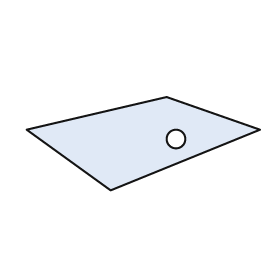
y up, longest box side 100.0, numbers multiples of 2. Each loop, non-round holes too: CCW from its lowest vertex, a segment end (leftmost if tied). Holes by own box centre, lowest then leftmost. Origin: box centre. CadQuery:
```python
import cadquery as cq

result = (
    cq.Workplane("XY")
    .moveTo(-14.0, -20.0)
    .lineTo(50.0, 6.0)
    .lineTo(10.0, 20.0)
    .lineTo(-50.0, 6.0)
    .close()
    .moveTo(14.0, 2.0)
    .circle(4.0)
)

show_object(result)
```